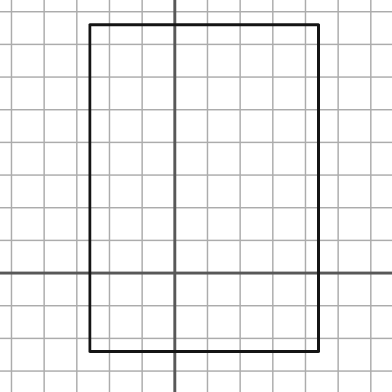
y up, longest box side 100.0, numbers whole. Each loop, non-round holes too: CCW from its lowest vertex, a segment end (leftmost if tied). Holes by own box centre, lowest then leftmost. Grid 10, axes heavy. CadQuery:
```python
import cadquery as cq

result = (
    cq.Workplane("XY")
    .moveTo(-26.0, -24.0)
    .lineTo(44.0, -24.0)
    .lineTo(44.0, 76.0)
    .lineTo(-26.0, 76.0)
    .close()
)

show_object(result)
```